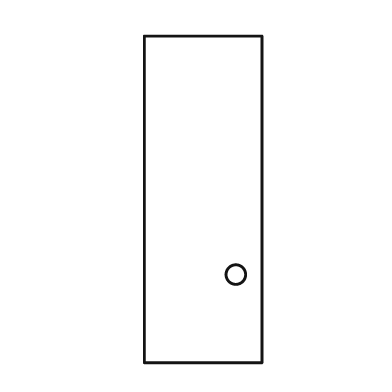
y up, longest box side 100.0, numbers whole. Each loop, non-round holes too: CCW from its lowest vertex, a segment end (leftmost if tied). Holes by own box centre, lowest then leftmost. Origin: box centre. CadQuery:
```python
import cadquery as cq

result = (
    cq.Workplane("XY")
    .moveTo(-18.0, -50.0)
    .lineTo(18.0, -50.0)
    .lineTo(18.0, 50.0)
    .lineTo(-18.0, 50.0)
    .close()
    .moveTo(10.0, -23.0)
    .circle(3.0)
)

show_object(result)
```